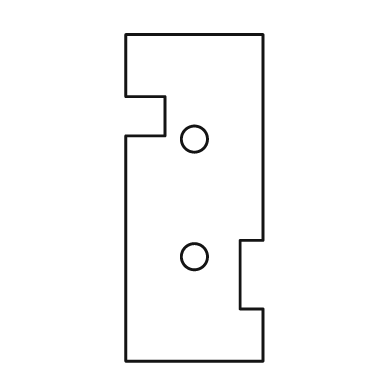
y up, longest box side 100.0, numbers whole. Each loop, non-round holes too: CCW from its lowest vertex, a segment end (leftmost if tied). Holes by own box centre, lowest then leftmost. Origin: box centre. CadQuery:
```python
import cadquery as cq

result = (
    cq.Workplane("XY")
    .moveTo(-21.0, -50.0)
    .lineTo(21.0, -50.0)
    .lineTo(21.0, -34.0)
    .lineTo(14.0, -34.0)
    .lineTo(14.0, -13.0)
    .lineTo(21.0, -13.0)
    .lineTo(21.0, 50.0)
    .lineTo(-21.0, 50.0)
    .lineTo(-21.0, 31.0)
    .lineTo(-9.0, 31.0)
    .lineTo(-9.0, 19.0)
    .lineTo(-21.0, 19.0)
    .close()
    .moveTo(0.0, -18.0)
    .circle(4.0)
    .moveTo(0.0, 18.0)
    .circle(4.0)
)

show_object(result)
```